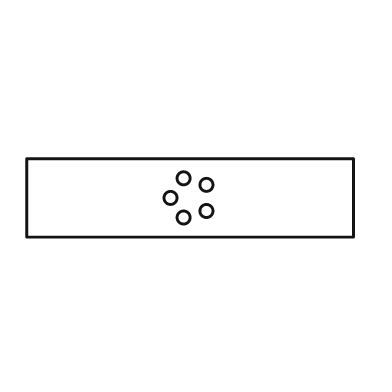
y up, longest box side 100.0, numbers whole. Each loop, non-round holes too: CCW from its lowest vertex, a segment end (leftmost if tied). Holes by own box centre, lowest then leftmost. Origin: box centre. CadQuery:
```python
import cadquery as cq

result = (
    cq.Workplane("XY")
    .moveTo(-50.0, -12.0)
    .lineTo(50.0, -12.0)
    .lineTo(50.0, 12.0)
    .lineTo(-50.0, 12.0)
    .close()
    .moveTo(-2.0, -6.0)
    .circle(2.0)
    .moveTo(5.0, -4.0)
    .circle(2.0)
    .moveTo(-6.0, 0.0)
    .circle(2.0)
    .moveTo(5.0, 4.0)
    .circle(2.0)
    .moveTo(-2.0, 6.0)
    .circle(2.0)
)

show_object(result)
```